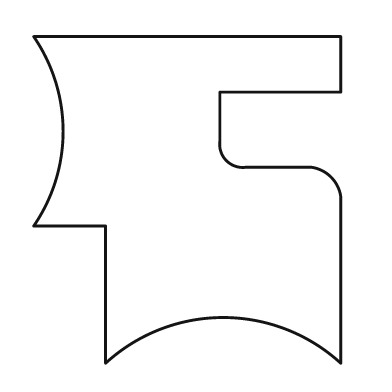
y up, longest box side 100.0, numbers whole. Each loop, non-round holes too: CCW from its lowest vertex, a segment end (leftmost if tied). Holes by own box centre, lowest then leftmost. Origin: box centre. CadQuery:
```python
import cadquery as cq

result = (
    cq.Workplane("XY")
    .moveTo(-25.0, -50.0)
    .threePointArc((11.0, -36.0), (47.0, -50.0))
    .lineTo(47.0, 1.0)
    .threePointArc((44.0, 7.0), (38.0, 10.0))
    .lineTo(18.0, 10.0)
    .threePointArc((12.0, 12.0), (10.0, 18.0))
    .lineTo(10.0, 33.0)
    .lineTo(47.0, 33.0)
    .lineTo(47.0, 50.0)
    .lineTo(-47.0, 50.0)
    .threePointArc((-38.0, 21.0), (-47.0, -8.0))
    .lineTo(-25.0, -8.0)
    .close()
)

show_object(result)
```